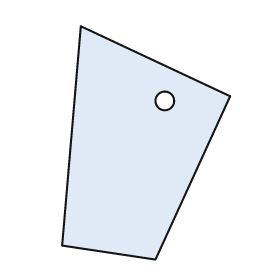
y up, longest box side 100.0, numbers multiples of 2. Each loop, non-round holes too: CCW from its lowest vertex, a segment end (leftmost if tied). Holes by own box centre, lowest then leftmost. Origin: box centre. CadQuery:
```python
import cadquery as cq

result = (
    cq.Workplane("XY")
    .moveTo(4.0, -50.0)
    .lineTo(36.0, 20.0)
    .lineTo(-28.0, 50.0)
    .lineTo(-36.0, -44.0)
    .close()
    .moveTo(8.0, 18.0)
    .circle(4.0)
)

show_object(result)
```